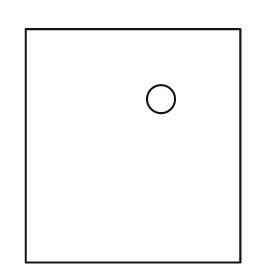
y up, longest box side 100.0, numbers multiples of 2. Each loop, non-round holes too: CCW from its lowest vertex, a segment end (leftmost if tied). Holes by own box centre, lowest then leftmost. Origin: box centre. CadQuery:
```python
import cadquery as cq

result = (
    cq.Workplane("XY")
    .moveTo(-46.0, -50.0)
    .lineTo(46.0, -50.0)
    .lineTo(46.0, 50.0)
    .lineTo(-46.0, 50.0)
    .close()
    .moveTo(12.0, 20.0)
    .circle(6.0)
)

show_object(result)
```